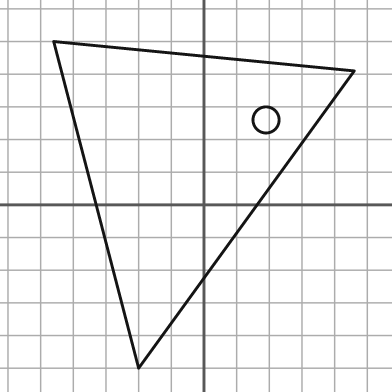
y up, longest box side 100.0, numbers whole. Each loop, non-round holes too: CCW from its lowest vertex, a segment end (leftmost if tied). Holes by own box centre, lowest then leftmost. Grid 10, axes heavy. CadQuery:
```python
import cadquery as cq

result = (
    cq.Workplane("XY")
    .moveTo(-20.0, -50.0)
    .lineTo(46.0, 41.0)
    .lineTo(-46.0, 50.0)
    .close()
    .moveTo(19.0, 26.0)
    .circle(4.0)
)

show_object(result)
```